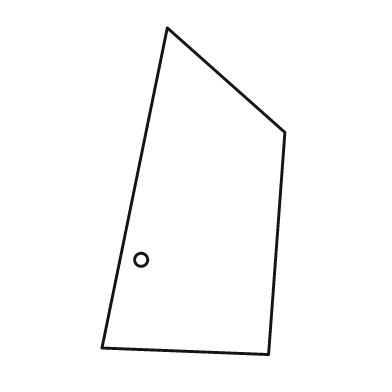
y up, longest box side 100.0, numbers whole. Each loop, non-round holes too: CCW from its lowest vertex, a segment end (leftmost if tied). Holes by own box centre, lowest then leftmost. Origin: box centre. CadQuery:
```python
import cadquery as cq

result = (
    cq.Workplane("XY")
    .moveTo(23.0, -50.0)
    .lineTo(28.0, 18.0)
    .lineTo(-8.0, 50.0)
    .lineTo(-28.0, -48.0)
    .close()
    .moveTo(-16.0, -21.0)
    .circle(2.0)
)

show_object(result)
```